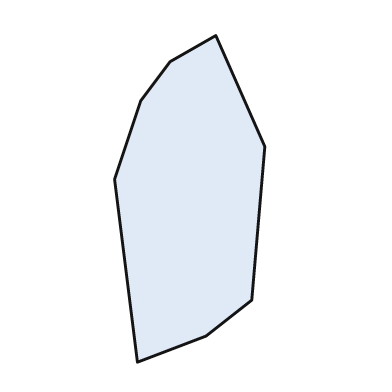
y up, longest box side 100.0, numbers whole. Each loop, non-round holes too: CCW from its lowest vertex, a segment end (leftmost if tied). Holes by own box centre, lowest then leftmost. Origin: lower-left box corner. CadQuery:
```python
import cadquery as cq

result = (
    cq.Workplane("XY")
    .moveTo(7.0, 0.0)
    .lineTo(28.0, 8.0)
    .lineTo(42.0, 19.0)
    .lineTo(46.0, 66.0)
    .lineTo(31.0, 100.0)
    .lineTo(17.0, 92.0)
    .lineTo(8.0, 80.0)
    .lineTo(0.0, 56.0)
    .close()
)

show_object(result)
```